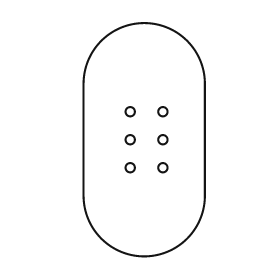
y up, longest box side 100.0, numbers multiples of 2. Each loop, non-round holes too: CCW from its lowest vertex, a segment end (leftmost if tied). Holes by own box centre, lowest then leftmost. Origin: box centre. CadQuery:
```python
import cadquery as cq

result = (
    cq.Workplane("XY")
    .moveTo(-26.0, -24.0)
    .threePointArc((0.0, -50.0), (26.0, -24.0))
    .lineTo(26.0, 24.0)
    .threePointArc((0.0, 50.0), (-26.0, 24.0))
    .close()
    .moveTo(-6.0, -12.0)
    .circle(2.0)
    .moveTo(8.0, -12.0)
    .circle(2.0)
    .moveTo(-6.0, 0.0)
    .circle(2.0)
    .moveTo(8.0, 0.0)
    .circle(2.0)
    .moveTo(-6.0, 12.0)
    .circle(2.0)
    .moveTo(8.0, 12.0)
    .circle(2.0)
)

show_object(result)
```